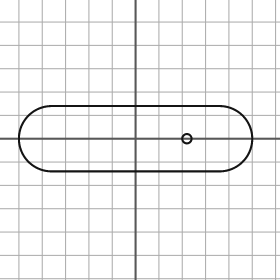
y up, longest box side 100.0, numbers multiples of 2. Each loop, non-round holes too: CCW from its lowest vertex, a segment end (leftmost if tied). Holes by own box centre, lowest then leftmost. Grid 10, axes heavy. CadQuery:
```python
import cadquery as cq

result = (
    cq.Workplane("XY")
    .moveTo(-36.0, -14.0)
    .lineTo(36.0, -14.0)
    .threePointArc((50.0, 0.0), (36.0, 14.0))
    .lineTo(-36.0, 14.0)
    .threePointArc((-50.0, 0.0), (-36.0, -14.0))
    .close()
    .moveTo(22.0, 0.0)
    .circle(2.0)
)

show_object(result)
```